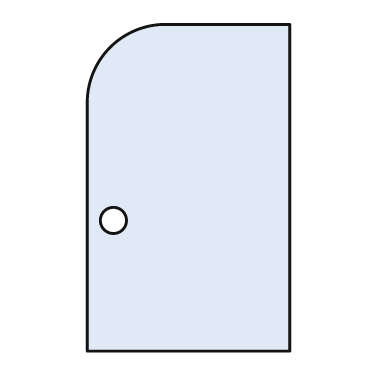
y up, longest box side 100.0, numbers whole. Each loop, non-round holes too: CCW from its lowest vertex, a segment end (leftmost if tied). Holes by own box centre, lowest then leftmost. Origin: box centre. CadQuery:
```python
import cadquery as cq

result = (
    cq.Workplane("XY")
    .moveTo(-31.0, -50.0)
    .lineTo(31.0, -50.0)
    .lineTo(31.0, 50.0)
    .lineTo(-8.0, 50.0)
    .threePointArc((-24.0, 43.0), (-31.0, 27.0))
    .close()
    .moveTo(-23.0, -10.0)
    .circle(4.0)
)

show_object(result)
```